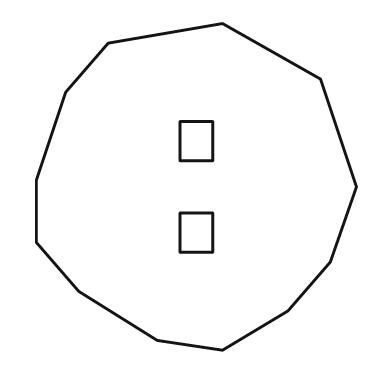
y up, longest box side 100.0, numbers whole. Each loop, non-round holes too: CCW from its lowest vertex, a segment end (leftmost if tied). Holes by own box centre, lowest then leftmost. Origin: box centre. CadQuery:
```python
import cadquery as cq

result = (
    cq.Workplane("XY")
    .moveTo(8.0, -50.0)
    .lineTo(28.0, -38.0)
    .lineTo(41.0, -23.0)
    .lineTo(49.0, 0.0)
    .lineTo(38.0, 33.0)
    .lineTo(8.0, 50.0)
    .lineTo(-27.0, 44.0)
    .lineTo(-40.0, 29.0)
    .lineTo(-49.0, 2.0)
    .lineTo(-49.0, -17.0)
    .lineTo(-36.0, -32.0)
    .lineTo(-12.0, -47.0)
    .close()
    .moveTo(-5.0, -20.0)
    .lineTo(5.0, -20.0)
    .lineTo(5.0, -8.0)
    .lineTo(-5.0, -8.0)
    .close()
    .moveTo(-5.0, 8.0)
    .lineTo(5.0, 8.0)
    .lineTo(5.0, 20.0)
    .lineTo(-5.0, 20.0)
    .close()
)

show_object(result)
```